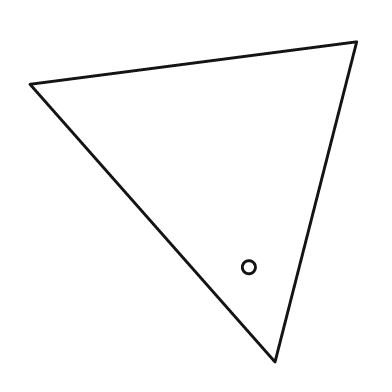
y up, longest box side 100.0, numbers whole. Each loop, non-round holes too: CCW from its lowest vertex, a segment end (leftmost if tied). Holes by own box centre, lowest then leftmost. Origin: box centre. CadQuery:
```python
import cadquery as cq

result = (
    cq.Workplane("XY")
    .moveTo(25.0, -49.0)
    .lineTo(50.0, 49.0)
    .lineTo(-50.0, 36.0)
    .close()
    .moveTo(17.0, -20.0)
    .circle(2.0)
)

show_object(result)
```